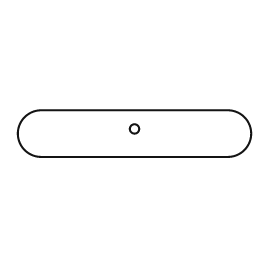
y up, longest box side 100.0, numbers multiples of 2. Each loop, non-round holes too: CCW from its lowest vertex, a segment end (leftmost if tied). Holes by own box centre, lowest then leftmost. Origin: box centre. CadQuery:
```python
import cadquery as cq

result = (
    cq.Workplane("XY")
    .moveTo(-40.0, -10.0)
    .lineTo(40.0, -10.0)
    .threePointArc((50.0, 0.0), (40.0, 10.0))
    .lineTo(-40.0, 10.0)
    .threePointArc((-50.0, 0.0), (-40.0, -10.0))
    .close()
    .moveTo(0.0, 2.0)
    .circle(2.0)
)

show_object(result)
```